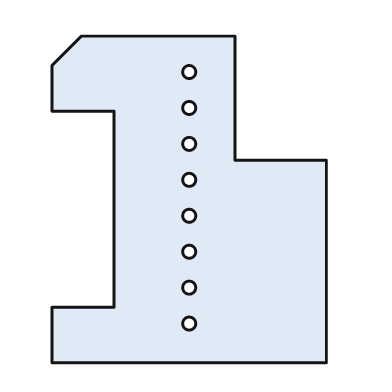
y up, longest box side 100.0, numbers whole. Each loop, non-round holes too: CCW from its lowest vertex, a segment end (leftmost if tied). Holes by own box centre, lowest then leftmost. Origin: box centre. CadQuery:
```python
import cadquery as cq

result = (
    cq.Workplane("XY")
    .moveTo(-42.0, -50.0)
    .lineTo(42.0, -50.0)
    .lineTo(42.0, 12.0)
    .lineTo(14.0, 12.0)
    .lineTo(14.0, 50.0)
    .lineTo(-33.0, 50.0)
    .lineTo(-42.0, 41.0)
    .lineTo(-42.0, 27.0)
    .lineTo(-23.0, 27.0)
    .lineTo(-23.0, -33.0)
    .lineTo(-42.0, -33.0)
    .close()
    .moveTo(0.0, -38.0)
    .circle(2.0)
    .moveTo(0.0, -27.0)
    .circle(2.0)
    .moveTo(0.0, -16.0)
    .circle(2.0)
    .moveTo(0.0, -5.0)
    .circle(2.0)
    .moveTo(0.0, 6.0)
    .circle(2.0)
    .moveTo(0.0, 17.0)
    .circle(2.0)
    .moveTo(0.0, 28.0)
    .circle(2.0)
    .moveTo(0.0, 39.0)
    .circle(2.0)
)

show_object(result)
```